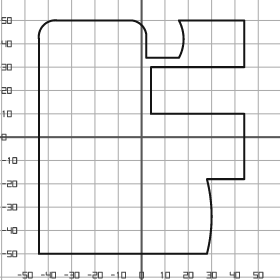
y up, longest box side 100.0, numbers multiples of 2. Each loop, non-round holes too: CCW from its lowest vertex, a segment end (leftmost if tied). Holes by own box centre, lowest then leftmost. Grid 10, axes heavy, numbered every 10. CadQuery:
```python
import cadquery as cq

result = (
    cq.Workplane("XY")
    .moveTo(-44.0, -50.0)
    .lineTo(28.0, -50.0)
    .threePointArc((30.0, -34.0), (28.0, -18.0))
    .lineTo(44.0, -18.0)
    .lineTo(44.0, 10.0)
    .lineTo(4.0, 10.0)
    .lineTo(4.0, 30.0)
    .lineTo(44.0, 30.0)
    .lineTo(44.0, 50.0)
    .lineTo(16.0, 50.0)
    .threePointArc((18.0, 42.0), (16.0, 34.0))
    .lineTo(2.0, 34.0)
    .lineTo(2.0, 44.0)
    .threePointArc((0.0, 48.0), (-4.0, 50.0))
    .lineTo(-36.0, 50.0)
    .threePointArc((-42.0, 48.0), (-44.0, 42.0))
    .close()
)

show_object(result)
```